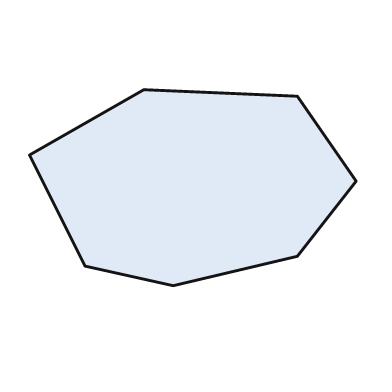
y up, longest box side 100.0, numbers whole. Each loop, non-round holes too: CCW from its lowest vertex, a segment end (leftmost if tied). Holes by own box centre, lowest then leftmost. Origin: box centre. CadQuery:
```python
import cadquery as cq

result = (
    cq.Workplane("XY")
    .moveTo(-6.0, -30.0)
    .lineTo(32.0, -21.0)
    .lineTo(50.0, 2.0)
    .lineTo(32.0, 28.0)
    .lineTo(-15.0, 30.0)
    .lineTo(-50.0, 10.0)
    .lineTo(-33.0, -24.0)
    .close()
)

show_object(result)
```